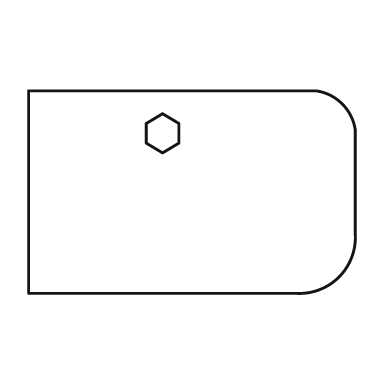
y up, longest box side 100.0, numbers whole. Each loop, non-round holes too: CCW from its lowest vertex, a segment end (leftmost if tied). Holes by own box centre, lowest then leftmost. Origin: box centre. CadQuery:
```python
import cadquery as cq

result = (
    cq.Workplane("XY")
    .moveTo(-50.0, -31.0)
    .lineTo(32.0, -31.0)
    .threePointArc((45.0, -26.0), (50.0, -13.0))
    .lineTo(50.0, 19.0)
    .threePointArc((46.0, 27.0), (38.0, 31.0))
    .lineTo(-50.0, 31.0)
    .close()
    .moveTo(-9.0, 12.0)
    .lineTo(-4.0, 15.0)
    .lineTo(-4.0, 21.0)
    .lineTo(-9.0, 24.0)
    .lineTo(-14.0, 21.0)
    .lineTo(-14.0, 15.0)
    .close()
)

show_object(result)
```